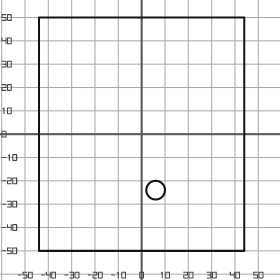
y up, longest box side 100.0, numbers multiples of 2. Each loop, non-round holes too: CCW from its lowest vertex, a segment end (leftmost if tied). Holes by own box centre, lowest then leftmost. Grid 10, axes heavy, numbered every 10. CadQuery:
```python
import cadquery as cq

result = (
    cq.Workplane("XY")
    .moveTo(-44.0, -50.0)
    .lineTo(44.0, -50.0)
    .lineTo(44.0, 50.0)
    .lineTo(-44.0, 50.0)
    .close()
    .moveTo(6.0, -24.0)
    .circle(4.0)
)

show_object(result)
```